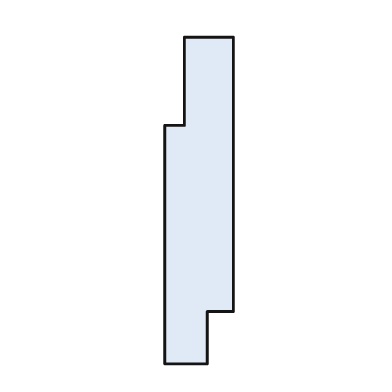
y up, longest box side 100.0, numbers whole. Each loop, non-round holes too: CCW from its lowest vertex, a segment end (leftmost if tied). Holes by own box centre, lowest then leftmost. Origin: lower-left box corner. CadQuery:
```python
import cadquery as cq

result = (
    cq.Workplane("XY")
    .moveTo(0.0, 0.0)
    .lineTo(13.0, 0.0)
    .lineTo(13.0, 16.0)
    .lineTo(21.0, 16.0)
    .lineTo(21.0, 100.0)
    .lineTo(6.0, 100.0)
    .lineTo(6.0, 73.0)
    .lineTo(0.0, 73.0)
    .close()
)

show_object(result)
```